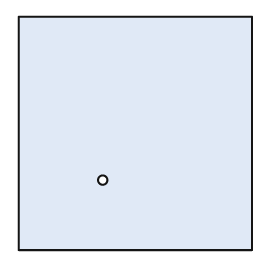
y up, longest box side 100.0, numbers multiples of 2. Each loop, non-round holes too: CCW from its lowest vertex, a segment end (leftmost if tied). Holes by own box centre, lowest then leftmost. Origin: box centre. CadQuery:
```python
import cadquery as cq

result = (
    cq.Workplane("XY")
    .moveTo(-50.0, -50.0)
    .lineTo(50.0, -50.0)
    .lineTo(50.0, 50.0)
    .lineTo(-50.0, 50.0)
    .close()
    .moveTo(-14.0, -20.0)
    .circle(2.0)
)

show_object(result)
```